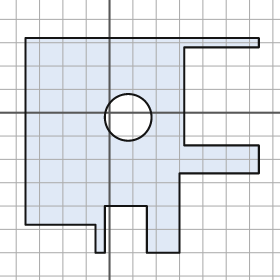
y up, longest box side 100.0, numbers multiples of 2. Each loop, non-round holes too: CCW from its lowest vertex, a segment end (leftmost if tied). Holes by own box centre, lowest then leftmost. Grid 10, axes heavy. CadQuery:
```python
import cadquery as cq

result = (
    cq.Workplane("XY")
    .moveTo(-6.0, -60.0)
    .lineTo(-2.0, -60.0)
    .lineTo(-2.0, -40.0)
    .lineTo(16.0, -40.0)
    .lineTo(16.0, -60.0)
    .lineTo(30.0, -60.0)
    .lineTo(30.0, -26.0)
    .lineTo(64.0, -26.0)
    .lineTo(64.0, -14.0)
    .lineTo(32.0, -14.0)
    .lineTo(32.0, 28.0)
    .lineTo(64.0, 28.0)
    .lineTo(64.0, 32.0)
    .lineTo(-36.0, 32.0)
    .lineTo(-36.0, -48.0)
    .lineTo(-6.0, -48.0)
    .close()
    .moveTo(8.0, -2.0)
    .circle(10.0)
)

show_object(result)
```